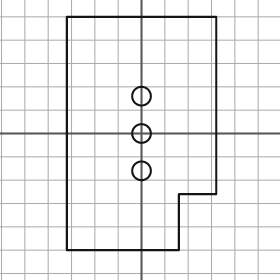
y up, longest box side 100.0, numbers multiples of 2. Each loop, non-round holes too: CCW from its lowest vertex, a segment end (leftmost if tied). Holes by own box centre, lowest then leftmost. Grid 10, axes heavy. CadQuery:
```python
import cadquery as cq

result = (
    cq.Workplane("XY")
    .moveTo(-32.0, -50.0)
    .lineTo(16.0, -50.0)
    .lineTo(16.0, -26.0)
    .lineTo(32.0, -26.0)
    .lineTo(32.0, 50.0)
    .lineTo(-32.0, 50.0)
    .close()
    .moveTo(0.0, -16.0)
    .circle(4.0)
    .moveTo(0.0, 0.0)
    .circle(4.0)
    .moveTo(0.0, 16.0)
    .circle(4.0)
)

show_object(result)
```